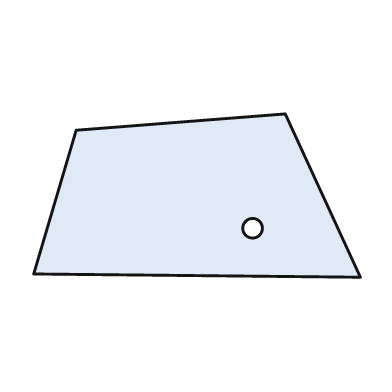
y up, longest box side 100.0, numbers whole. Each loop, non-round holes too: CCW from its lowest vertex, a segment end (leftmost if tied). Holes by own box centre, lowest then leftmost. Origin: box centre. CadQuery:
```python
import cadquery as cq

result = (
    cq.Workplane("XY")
    .moveTo(50.0, -25.0)
    .lineTo(27.0, 25.0)
    .lineTo(-37.0, 20.0)
    .lineTo(-50.0, -24.0)
    .close()
    .moveTo(17.0, -10.0)
    .circle(3.0)
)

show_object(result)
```